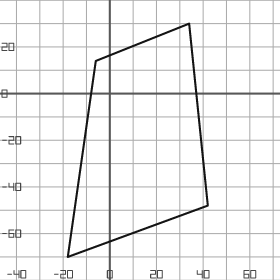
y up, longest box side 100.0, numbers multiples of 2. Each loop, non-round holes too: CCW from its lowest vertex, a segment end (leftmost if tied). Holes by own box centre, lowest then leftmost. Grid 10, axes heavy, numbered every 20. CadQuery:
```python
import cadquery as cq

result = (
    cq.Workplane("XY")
    .moveTo(-18.0, -70.0)
    .lineTo(42.0, -48.0)
    .lineTo(34.0, 30.0)
    .lineTo(-6.0, 14.0)
    .close()
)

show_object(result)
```